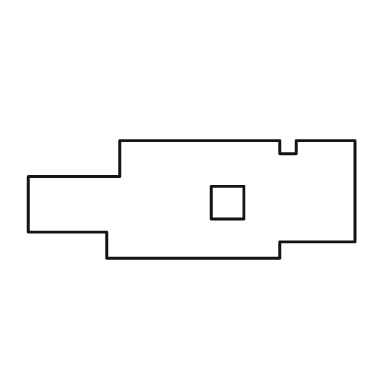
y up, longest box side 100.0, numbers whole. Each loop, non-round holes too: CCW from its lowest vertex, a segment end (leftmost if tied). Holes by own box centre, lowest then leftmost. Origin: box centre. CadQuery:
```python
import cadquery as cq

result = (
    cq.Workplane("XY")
    .moveTo(-26.0, -18.0)
    .lineTo(27.0, -18.0)
    .lineTo(27.0, -13.0)
    .lineTo(50.0, -13.0)
    .lineTo(50.0, 18.0)
    .lineTo(32.0, 18.0)
    .lineTo(32.0, 14.0)
    .lineTo(27.0, 14.0)
    .lineTo(27.0, 18.0)
    .lineTo(-22.0, 18.0)
    .lineTo(-22.0, 7.0)
    .lineTo(-50.0, 7.0)
    .lineTo(-50.0, -10.0)
    .lineTo(-26.0, -10.0)
    .close()
    .moveTo(6.0, -6.0)
    .lineTo(16.0, -6.0)
    .lineTo(16.0, 4.0)
    .lineTo(6.0, 4.0)
    .close()
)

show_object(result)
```